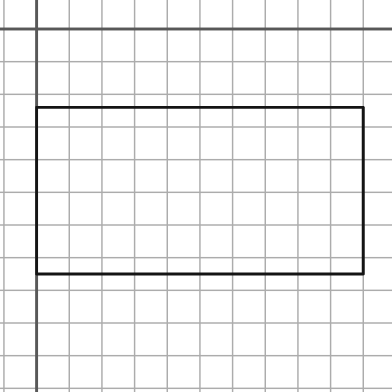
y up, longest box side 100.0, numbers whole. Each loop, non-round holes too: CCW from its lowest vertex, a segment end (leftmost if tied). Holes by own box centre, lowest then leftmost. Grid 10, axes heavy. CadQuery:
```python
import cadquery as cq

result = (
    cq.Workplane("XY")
    .moveTo(0.0, -75.0)
    .lineTo(100.0, -75.0)
    .lineTo(100.0, -24.0)
    .lineTo(0.0, -24.0)
    .close()
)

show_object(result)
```